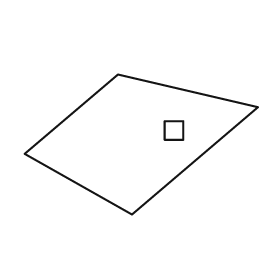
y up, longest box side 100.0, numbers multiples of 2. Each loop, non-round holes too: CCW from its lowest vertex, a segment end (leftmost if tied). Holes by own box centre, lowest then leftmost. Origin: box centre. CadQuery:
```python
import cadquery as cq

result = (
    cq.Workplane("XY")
    .moveTo(-4.0, -30.0)
    .lineTo(50.0, 16.0)
    .lineTo(-10.0, 30.0)
    .lineTo(-50.0, -4.0)
    .close()
    .moveTo(10.0, 2.0)
    .lineTo(18.0, 2.0)
    .lineTo(18.0, 10.0)
    .lineTo(10.0, 10.0)
    .close()
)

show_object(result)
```